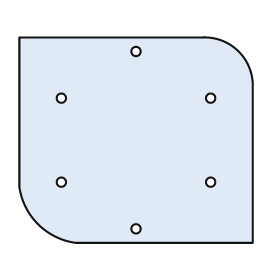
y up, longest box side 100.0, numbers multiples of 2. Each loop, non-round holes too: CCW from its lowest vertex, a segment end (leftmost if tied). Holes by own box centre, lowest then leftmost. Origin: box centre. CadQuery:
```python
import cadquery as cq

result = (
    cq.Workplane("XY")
    .moveTo(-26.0, -44.0)
    .lineTo(50.0, -44.0)
    .lineTo(50.0, 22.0)
    .threePointArc((44.0, 38.0), (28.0, 44.0))
    .lineTo(-50.0, 44.0)
    .lineTo(-50.0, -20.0)
    .threePointArc((-42.0, -36.0), (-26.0, -44.0))
    .close()
    .moveTo(0.0, -38.0)
    .circle(2.0)
    .moveTo(-32.0, -18.0)
    .circle(2.0)
    .moveTo(32.0, -18.0)
    .circle(2.0)
    .moveTo(-32.0, 18.0)
    .circle(2.0)
    .moveTo(32.0, 18.0)
    .circle(2.0)
    .moveTo(0.0, 38.0)
    .circle(2.0)
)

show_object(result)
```